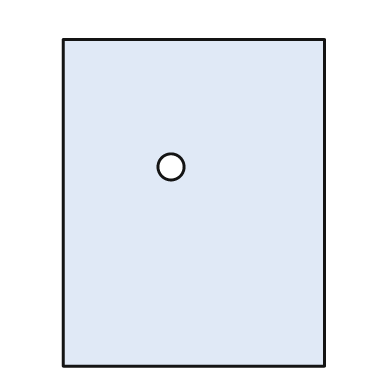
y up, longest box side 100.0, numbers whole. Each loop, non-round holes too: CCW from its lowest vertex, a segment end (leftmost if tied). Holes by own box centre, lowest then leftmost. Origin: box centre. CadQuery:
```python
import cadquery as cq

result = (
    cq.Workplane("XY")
    .moveTo(-40.0, -50.0)
    .lineTo(40.0, -50.0)
    .lineTo(40.0, 50.0)
    .lineTo(-40.0, 50.0)
    .close()
    .moveTo(-7.0, 11.0)
    .circle(4.0)
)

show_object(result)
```